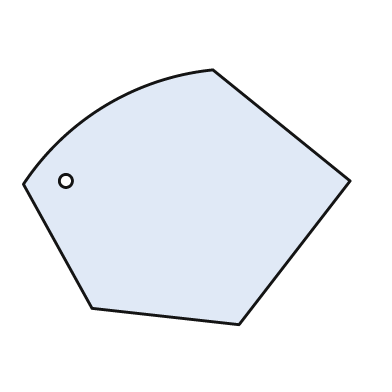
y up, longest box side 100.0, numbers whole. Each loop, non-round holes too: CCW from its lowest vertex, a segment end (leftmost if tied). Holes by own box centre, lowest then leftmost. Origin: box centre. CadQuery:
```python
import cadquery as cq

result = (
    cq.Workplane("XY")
    .moveTo(16.0, -39.0)
    .lineTo(50.0, 5.0)
    .lineTo(8.0, 39.0)
    .threePointArc((-25.0, 28.0), (-50.0, 4.0))
    .lineTo(-29.0, -34.0)
    .close()
    .moveTo(-37.0, 5.0)
    .circle(2.0)
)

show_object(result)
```